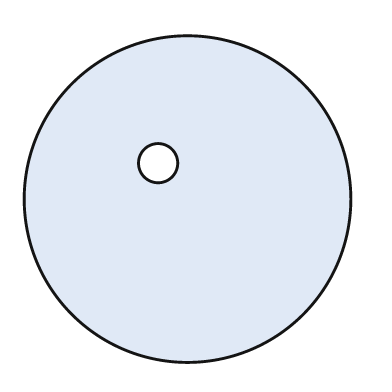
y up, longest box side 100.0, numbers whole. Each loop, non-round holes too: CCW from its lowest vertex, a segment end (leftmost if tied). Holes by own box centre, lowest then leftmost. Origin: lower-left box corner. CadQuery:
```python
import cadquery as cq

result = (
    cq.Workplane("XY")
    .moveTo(50.0, 50.0)
    .circle(50.0)
    .moveTo(41.0, 61.0)
    .circle(6.0)
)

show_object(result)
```